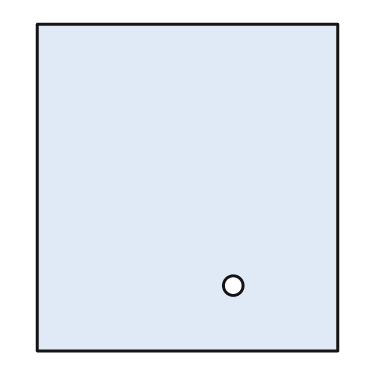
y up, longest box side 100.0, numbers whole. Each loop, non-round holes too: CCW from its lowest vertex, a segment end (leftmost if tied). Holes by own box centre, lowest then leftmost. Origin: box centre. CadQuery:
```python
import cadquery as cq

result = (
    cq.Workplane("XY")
    .moveTo(-46.0, -50.0)
    .lineTo(46.0, -50.0)
    .lineTo(46.0, 50.0)
    .lineTo(-46.0, 50.0)
    .close()
    .moveTo(14.0, -30.0)
    .circle(3.0)
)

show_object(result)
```